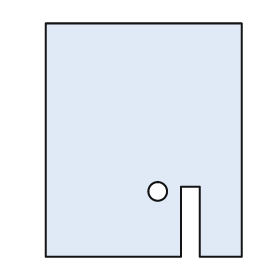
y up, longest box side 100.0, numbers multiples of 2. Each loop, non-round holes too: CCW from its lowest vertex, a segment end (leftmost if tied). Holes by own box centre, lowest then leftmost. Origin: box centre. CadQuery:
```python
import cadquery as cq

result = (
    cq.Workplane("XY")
    .moveTo(-42.0, -50.0)
    .lineTo(16.0, -50.0)
    .lineTo(16.0, -20.0)
    .lineTo(24.0, -20.0)
    .lineTo(24.0, -50.0)
    .lineTo(42.0, -50.0)
    .lineTo(42.0, 50.0)
    .lineTo(-42.0, 50.0)
    .close()
    .moveTo(6.0, -22.0)
    .circle(4.0)
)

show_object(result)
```